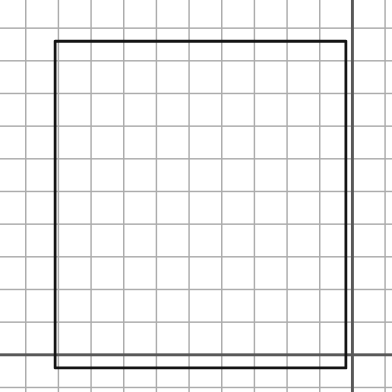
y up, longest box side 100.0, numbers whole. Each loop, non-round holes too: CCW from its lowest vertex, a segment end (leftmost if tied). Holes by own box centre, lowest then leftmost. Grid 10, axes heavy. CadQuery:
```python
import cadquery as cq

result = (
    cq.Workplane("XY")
    .moveTo(-91.0, -4.0)
    .lineTo(-2.0, -4.0)
    .lineTo(-2.0, 96.0)
    .lineTo(-91.0, 96.0)
    .close()
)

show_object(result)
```